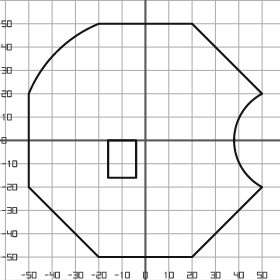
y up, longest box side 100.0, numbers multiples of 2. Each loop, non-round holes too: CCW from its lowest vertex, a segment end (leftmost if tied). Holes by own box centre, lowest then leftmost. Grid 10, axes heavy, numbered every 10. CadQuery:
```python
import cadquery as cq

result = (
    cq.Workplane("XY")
    .moveTo(-20.0, -50.0)
    .lineTo(20.0, -50.0)
    .lineTo(50.0, -20.0)
    .threePointArc((38.0, 0.0), (50.0, 20.0))
    .lineTo(20.0, 50.0)
    .lineTo(-20.0, 50.0)
    .threePointArc((-38.0, 38.0), (-50.0, 20.0))
    .lineTo(-50.0, -20.0)
    .close()
    .moveTo(-16.0, -16.0)
    .lineTo(-4.0, -16.0)
    .lineTo(-4.0, 0.0)
    .lineTo(-16.0, 0.0)
    .close()
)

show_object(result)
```